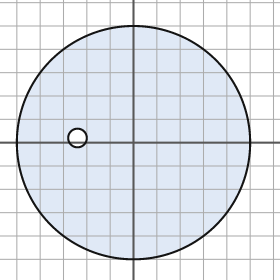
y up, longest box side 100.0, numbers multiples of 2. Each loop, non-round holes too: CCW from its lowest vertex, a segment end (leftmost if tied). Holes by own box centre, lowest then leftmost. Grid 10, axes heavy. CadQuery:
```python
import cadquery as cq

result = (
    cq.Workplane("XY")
    .moveTo(0.0, 0.0)
    .circle(50.0)
    .moveTo(-24.0, 2.0)
    .circle(4.0)
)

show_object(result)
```